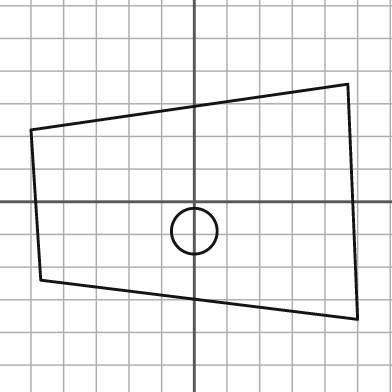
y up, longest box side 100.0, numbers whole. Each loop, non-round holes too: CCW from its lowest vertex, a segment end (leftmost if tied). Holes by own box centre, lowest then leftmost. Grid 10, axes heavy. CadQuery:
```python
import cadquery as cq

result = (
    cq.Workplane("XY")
    .moveTo(50.0, -36.0)
    .lineTo(47.0, 36.0)
    .lineTo(-50.0, 22.0)
    .lineTo(-47.0, -24.0)
    .close()
    .moveTo(0.0, -9.0)
    .circle(7.0)
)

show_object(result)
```